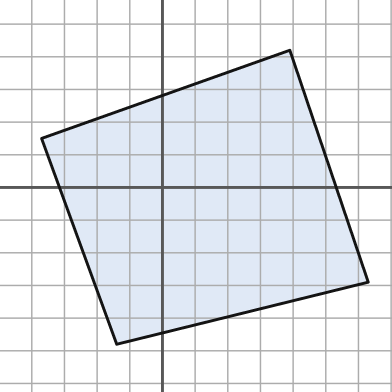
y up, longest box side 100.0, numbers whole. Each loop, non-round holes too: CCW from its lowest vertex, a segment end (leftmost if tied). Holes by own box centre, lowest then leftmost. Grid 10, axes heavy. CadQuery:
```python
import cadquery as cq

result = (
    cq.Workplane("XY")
    .moveTo(-14.0, -48.0)
    .lineTo(63.0, -29.0)
    .lineTo(39.0, 42.0)
    .lineTo(-37.0, 15.0)
    .close()
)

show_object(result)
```